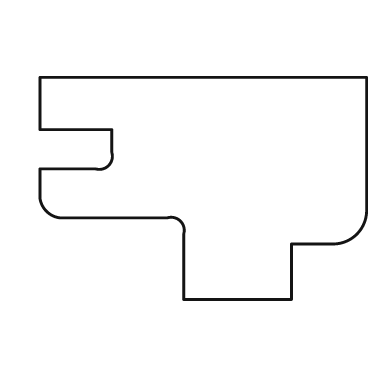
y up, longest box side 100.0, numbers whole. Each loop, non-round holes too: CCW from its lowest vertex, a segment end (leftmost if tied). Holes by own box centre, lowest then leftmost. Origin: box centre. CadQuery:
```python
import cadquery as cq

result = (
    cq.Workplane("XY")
    .moveTo(-6.0, -34.0)
    .lineTo(27.0, -34.0)
    .lineTo(27.0, -17.0)
    .lineTo(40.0, -17.0)
    .threePointArc((47.0, -14.0), (50.0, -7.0))
    .lineTo(50.0, 34.0)
    .lineTo(-50.0, 34.0)
    .lineTo(-50.0, 18.0)
    .lineTo(-28.0, 18.0)
    .lineTo(-28.0, 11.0)
    .threePointArc((-29.0, 7.0), (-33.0, 6.0))
    .lineTo(-50.0, 6.0)
    .lineTo(-50.0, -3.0)
    .threePointArc((-48.0, -7.0), (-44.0, -9.0))
    .lineTo(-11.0, -9.0)
    .threePointArc((-7.0, -10.0), (-6.0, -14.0))
    .close()
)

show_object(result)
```